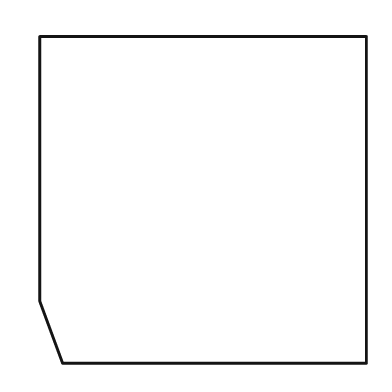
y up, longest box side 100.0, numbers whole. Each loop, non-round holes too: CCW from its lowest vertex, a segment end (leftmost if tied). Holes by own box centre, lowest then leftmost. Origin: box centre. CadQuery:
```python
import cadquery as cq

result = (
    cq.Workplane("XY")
    .moveTo(-43.0, -50.0)
    .lineTo(50.0, -50.0)
    .lineTo(50.0, 50.0)
    .lineTo(-50.0, 50.0)
    .lineTo(-50.0, -31.0)
    .close()
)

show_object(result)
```